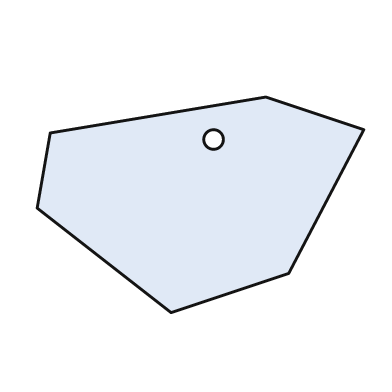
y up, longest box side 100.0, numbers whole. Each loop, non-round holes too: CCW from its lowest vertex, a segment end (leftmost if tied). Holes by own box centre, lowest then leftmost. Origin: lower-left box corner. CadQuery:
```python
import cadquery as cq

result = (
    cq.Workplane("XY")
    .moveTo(41.0, 0.0)
    .lineTo(77.0, 12.0)
    .lineTo(100.0, 56.0)
    .lineTo(70.0, 66.0)
    .lineTo(4.0, 55.0)
    .lineTo(0.0, 32.0)
    .close()
    .moveTo(54.0, 53.0)
    .circle(3.0)
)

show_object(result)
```